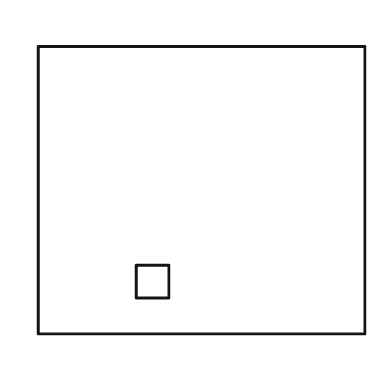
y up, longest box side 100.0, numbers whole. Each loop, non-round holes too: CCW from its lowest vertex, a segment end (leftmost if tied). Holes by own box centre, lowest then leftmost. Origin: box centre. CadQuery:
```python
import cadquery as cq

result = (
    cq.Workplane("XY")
    .moveTo(-50.0, -44.0)
    .lineTo(50.0, -44.0)
    .lineTo(50.0, 44.0)
    .lineTo(-50.0, 44.0)
    .close()
    .moveTo(-20.0, -33.0)
    .lineTo(-10.0, -33.0)
    .lineTo(-10.0, -23.0)
    .lineTo(-20.0, -23.0)
    .close()
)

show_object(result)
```